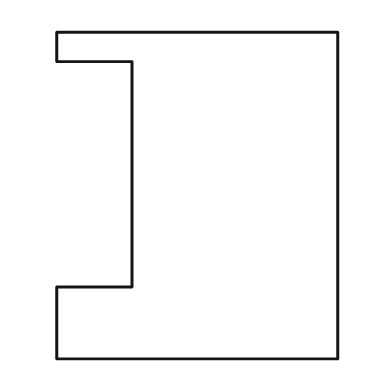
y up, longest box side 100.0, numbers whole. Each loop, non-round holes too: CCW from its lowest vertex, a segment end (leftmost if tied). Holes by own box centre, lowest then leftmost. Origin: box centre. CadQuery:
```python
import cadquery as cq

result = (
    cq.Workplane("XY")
    .moveTo(-43.0, -50.0)
    .lineTo(43.0, -50.0)
    .lineTo(43.0, 50.0)
    .lineTo(-43.0, 50.0)
    .lineTo(-43.0, 41.0)
    .lineTo(-20.0, 41.0)
    .lineTo(-20.0, -28.0)
    .lineTo(-43.0, -28.0)
    .close()
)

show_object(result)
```